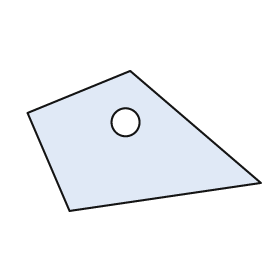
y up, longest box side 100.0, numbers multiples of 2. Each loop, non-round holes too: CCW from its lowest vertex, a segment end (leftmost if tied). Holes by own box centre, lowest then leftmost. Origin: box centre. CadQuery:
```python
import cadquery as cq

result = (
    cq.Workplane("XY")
    .moveTo(-32.0, -30.0)
    .lineTo(50.0, -18.0)
    .lineTo(-6.0, 30.0)
    .lineTo(-50.0, 12.0)
    .close()
    .moveTo(-8.0, 8.0)
    .circle(6.0)
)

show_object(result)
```